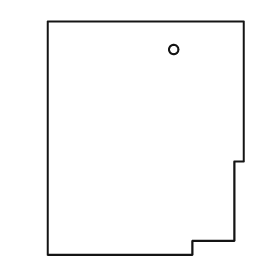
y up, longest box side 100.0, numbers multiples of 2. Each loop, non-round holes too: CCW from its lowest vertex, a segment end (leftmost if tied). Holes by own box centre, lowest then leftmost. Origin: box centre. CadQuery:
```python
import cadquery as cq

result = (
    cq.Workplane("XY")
    .moveTo(-42.0, -50.0)
    .lineTo(20.0, -50.0)
    .lineTo(20.0, -44.0)
    .lineTo(38.0, -44.0)
    .lineTo(38.0, -10.0)
    .lineTo(42.0, -10.0)
    .lineTo(42.0, 50.0)
    .lineTo(-42.0, 50.0)
    .close()
    .moveTo(12.0, 38.0)
    .circle(2.0)
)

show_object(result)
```